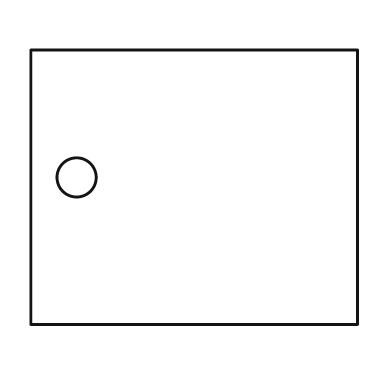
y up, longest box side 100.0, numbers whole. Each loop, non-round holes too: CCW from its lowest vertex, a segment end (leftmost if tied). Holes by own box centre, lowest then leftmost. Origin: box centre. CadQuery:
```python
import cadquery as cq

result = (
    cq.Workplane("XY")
    .moveTo(-50.0, -42.0)
    .lineTo(50.0, -42.0)
    .lineTo(50.0, 42.0)
    .lineTo(-50.0, 42.0)
    .close()
    .moveTo(-36.0, 3.0)
    .circle(6.0)
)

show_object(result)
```